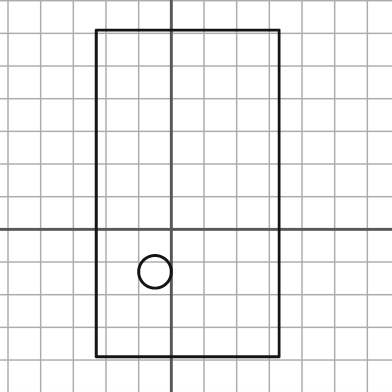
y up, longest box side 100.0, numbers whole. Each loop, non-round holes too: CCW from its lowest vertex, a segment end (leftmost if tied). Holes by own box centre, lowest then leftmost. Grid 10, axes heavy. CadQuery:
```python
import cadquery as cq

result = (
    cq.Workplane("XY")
    .moveTo(-23.0, -39.0)
    .lineTo(33.0, -39.0)
    .lineTo(33.0, 61.0)
    .lineTo(-23.0, 61.0)
    .close()
    .moveTo(-5.0, -13.0)
    .circle(5.0)
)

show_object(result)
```